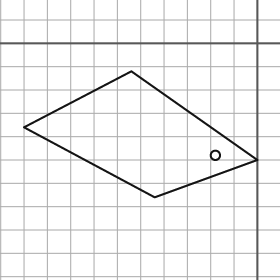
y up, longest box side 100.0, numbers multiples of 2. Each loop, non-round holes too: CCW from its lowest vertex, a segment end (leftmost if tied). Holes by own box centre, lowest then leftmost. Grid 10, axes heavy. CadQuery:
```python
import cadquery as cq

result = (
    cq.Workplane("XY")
    .moveTo(-44.0, -66.0)
    .lineTo(0.0, -50.0)
    .lineTo(-54.0, -12.0)
    .lineTo(-100.0, -36.0)
    .close()
    .moveTo(-18.0, -48.0)
    .circle(2.0)
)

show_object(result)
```